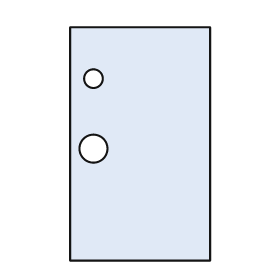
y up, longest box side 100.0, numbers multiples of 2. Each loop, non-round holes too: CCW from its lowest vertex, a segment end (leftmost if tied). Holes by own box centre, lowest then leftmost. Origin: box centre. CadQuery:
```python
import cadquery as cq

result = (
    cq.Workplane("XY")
    .moveTo(-30.0, -50.0)
    .lineTo(30.0, -50.0)
    .lineTo(30.0, 50.0)
    .lineTo(-30.0, 50.0)
    .close()
    .moveTo(-20.0, -2.0)
    .circle(6.0)
    .moveTo(-20.0, 28.0)
    .circle(4.0)
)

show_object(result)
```